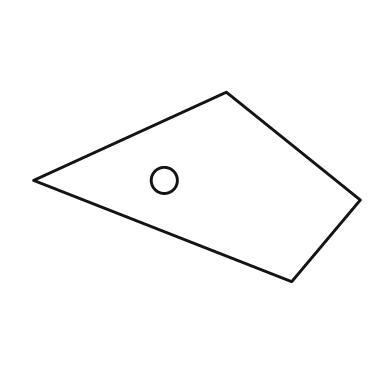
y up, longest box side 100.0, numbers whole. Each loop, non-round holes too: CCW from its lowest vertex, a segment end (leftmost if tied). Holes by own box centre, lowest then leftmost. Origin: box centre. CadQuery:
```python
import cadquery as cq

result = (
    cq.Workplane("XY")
    .moveTo(29.0, -29.0)
    .lineTo(50.0, -4.0)
    .lineTo(9.0, 29.0)
    .lineTo(-50.0, 2.0)
    .close()
    .moveTo(-10.0, 2.0)
    .circle(4.0)
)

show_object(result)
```